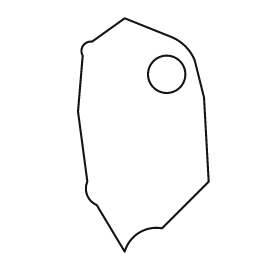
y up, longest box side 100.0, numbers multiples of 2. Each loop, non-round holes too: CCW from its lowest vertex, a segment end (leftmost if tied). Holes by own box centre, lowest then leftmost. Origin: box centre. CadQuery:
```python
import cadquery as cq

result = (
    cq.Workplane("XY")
    .moveTo(-8.0, -50.0)
    .threePointArc((-2.0, -42.0), (8.0, -40.0))
    .lineTo(28.0, -20.0)
    .lineTo(26.0, 16.0)
    .lineTo(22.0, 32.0)
    .threePointArc((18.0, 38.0), (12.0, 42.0))
    .lineTo(-8.0, 50.0)
    .lineTo(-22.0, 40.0)
    .threePointArc((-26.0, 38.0), (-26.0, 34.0))
    .lineTo(-28.0, 10.0)
    .lineTo(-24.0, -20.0)
    .threePointArc((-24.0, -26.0), (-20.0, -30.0))
    .close()
    .moveTo(10.0, 26.0)
    .circle(8.0)
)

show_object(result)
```